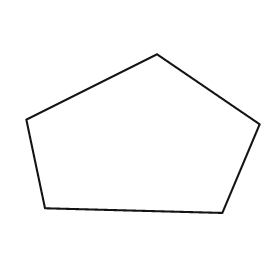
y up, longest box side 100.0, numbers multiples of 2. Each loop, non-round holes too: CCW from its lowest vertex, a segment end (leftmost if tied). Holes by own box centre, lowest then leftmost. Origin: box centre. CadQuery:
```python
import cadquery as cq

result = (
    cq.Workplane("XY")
    .moveTo(34.0, -34.0)
    .lineTo(50.0, 4.0)
    .lineTo(6.0, 34.0)
    .lineTo(-50.0, 6.0)
    .lineTo(-42.0, -32.0)
    .close()
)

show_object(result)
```